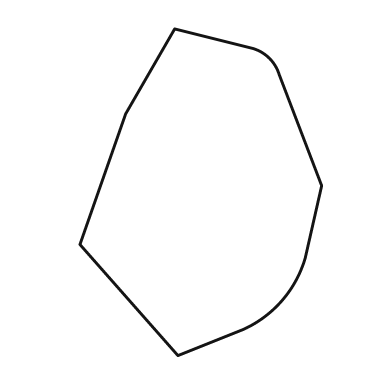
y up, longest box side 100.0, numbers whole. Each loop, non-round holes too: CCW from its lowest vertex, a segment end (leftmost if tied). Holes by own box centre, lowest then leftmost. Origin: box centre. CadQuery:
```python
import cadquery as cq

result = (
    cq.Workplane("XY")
    .moveTo(-7.0, -50.0)
    .lineTo(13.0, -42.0)
    .threePointArc((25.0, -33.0), (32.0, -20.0))
    .lineTo(37.0, 2.0)
    .lineTo(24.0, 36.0)
    .threePointArc((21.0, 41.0), (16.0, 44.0))
    .lineTo(-8.0, 50.0)
    .lineTo(-23.0, 24.0)
    .lineTo(-37.0, -16.0)
    .close()
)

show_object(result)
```